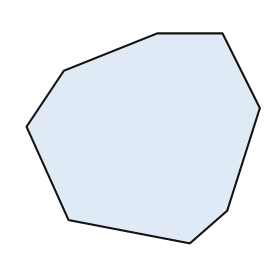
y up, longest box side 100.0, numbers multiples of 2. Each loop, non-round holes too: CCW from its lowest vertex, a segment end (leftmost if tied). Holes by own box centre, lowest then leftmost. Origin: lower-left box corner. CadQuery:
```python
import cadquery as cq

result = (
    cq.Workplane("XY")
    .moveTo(70.0, 0.0)
    .lineTo(86.0, 14.0)
    .lineTo(100.0, 58.0)
    .lineTo(84.0, 90.0)
    .lineTo(56.0, 90.0)
    .lineTo(16.0, 74.0)
    .lineTo(0.0, 50.0)
    .lineTo(18.0, 10.0)
    .close()
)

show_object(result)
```